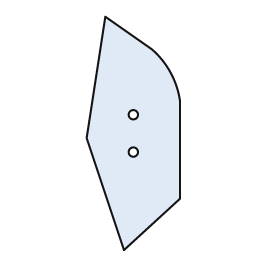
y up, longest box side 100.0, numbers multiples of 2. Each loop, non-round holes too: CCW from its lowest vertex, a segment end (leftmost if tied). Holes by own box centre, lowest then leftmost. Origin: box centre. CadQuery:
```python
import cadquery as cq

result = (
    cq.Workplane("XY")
    .moveTo(-4.0, -50.0)
    .lineTo(20.0, -28.0)
    .lineTo(20.0, 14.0)
    .threePointArc((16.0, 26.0), (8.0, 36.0))
    .lineTo(-12.0, 50.0)
    .lineTo(-20.0, -2.0)
    .close()
    .moveTo(0.0, -8.0)
    .circle(2.0)
    .moveTo(0.0, 8.0)
    .circle(2.0)
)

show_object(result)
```